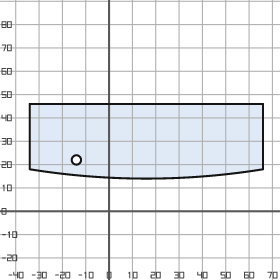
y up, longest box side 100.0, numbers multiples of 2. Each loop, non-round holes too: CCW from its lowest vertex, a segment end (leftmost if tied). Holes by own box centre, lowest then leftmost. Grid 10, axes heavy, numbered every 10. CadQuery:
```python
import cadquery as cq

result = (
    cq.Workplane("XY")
    .moveTo(-34.0, 18.0)
    .threePointArc((16.0, 14.0), (66.0, 18.0))
    .lineTo(66.0, 46.0)
    .lineTo(-34.0, 46.0)
    .close()
    .moveTo(-14.0, 22.0)
    .circle(2.0)
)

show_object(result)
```